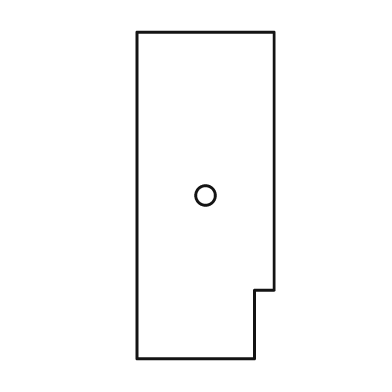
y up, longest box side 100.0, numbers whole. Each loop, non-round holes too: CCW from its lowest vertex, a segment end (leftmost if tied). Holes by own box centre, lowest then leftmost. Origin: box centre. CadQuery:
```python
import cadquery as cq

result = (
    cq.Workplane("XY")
    .moveTo(-21.0, -50.0)
    .lineTo(15.0, -50.0)
    .lineTo(15.0, -29.0)
    .lineTo(21.0, -29.0)
    .lineTo(21.0, 50.0)
    .lineTo(-21.0, 50.0)
    .close()
    .moveTo(0.0, 0.0)
    .circle(3.0)
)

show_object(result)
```